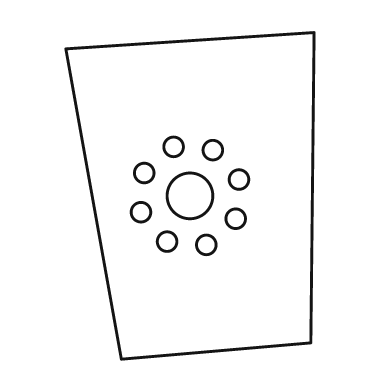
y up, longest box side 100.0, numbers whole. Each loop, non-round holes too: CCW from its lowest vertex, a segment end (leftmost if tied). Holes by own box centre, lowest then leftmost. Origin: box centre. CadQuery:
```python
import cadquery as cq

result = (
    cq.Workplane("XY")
    .moveTo(-21.0, -50.0)
    .lineTo(37.0, -45.0)
    .lineTo(38.0, 50.0)
    .lineTo(-38.0, 45.0)
    .close()
    .moveTo(5.0, -15.0)
    .circle(3.0)
    .moveTo(-7.0, -14.0)
    .circle(3.0)
    .moveTo(14.0, -7.0)
    .circle(3.0)
    .moveTo(-15.0, -5.0)
    .circle(3.0)
    .moveTo(0.0, 0.0)
    .circle(7.0)
    .moveTo(15.0, 5.0)
    .circle(3.0)
    .moveTo(-14.0, 7.0)
    .circle(3.0)
    .moveTo(7.0, 14.0)
    .circle(3.0)
    .moveTo(-5.0, 15.0)
    .circle(3.0)
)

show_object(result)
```